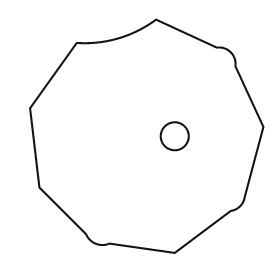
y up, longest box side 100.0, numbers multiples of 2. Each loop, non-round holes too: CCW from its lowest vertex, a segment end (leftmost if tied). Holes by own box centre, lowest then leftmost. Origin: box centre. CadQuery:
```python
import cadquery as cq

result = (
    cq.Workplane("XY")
    .moveTo(12.0, -50.0)
    .lineTo(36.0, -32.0)
    .threePointArc((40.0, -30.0), (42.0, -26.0))
    .lineTo(50.0, 4.0)
    .lineTo(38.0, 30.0)
    .threePointArc((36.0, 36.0), (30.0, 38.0))
    .lineTo(4.0, 50.0)
    .threePointArc((-12.0, 42.0), (-30.0, 40.0))
    .lineTo(-50.0, 12.0)
    .lineTo(-46.0, -22.0)
    .lineTo(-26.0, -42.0)
    .threePointArc((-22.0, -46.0), (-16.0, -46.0))
    .close()
    .moveTo(12.0, 0.0)
    .circle(6.0)
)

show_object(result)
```